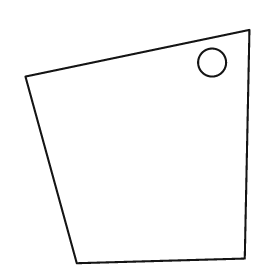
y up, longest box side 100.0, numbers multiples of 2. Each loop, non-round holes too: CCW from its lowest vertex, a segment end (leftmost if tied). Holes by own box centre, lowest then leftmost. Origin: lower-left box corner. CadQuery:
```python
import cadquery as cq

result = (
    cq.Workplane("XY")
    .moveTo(22.0, 0.0)
    .lineTo(94.0, 2.0)
    .lineTo(96.0, 100.0)
    .lineTo(0.0, 80.0)
    .close()
    .moveTo(80.0, 86.0)
    .circle(6.0)
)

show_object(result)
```